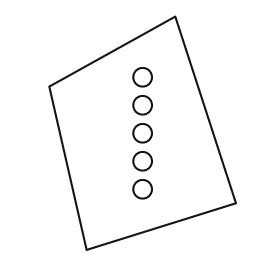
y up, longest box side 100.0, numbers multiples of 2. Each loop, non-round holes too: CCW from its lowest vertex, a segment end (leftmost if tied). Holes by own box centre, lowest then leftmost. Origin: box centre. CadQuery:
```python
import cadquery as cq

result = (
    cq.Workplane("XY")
    .moveTo(-24.0, -50.0)
    .lineTo(40.0, -30.0)
    .lineTo(14.0, 50.0)
    .lineTo(-40.0, 20.0)
    .close()
    .moveTo(0.0, -24.0)
    .circle(4.0)
    .moveTo(0.0, -12.0)
    .circle(4.0)
    .moveTo(0.0, 0.0)
    .circle(4.0)
    .moveTo(0.0, 12.0)
    .circle(4.0)
    .moveTo(0.0, 24.0)
    .circle(4.0)
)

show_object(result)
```